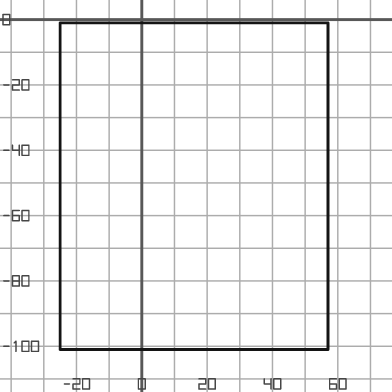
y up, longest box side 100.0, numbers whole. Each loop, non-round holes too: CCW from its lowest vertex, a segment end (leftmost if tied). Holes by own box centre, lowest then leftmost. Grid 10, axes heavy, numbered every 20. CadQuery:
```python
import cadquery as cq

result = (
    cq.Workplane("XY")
    .moveTo(-25.0, -101.0)
    .lineTo(57.0, -101.0)
    .lineTo(57.0, -1.0)
    .lineTo(-25.0, -1.0)
    .close()
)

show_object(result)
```